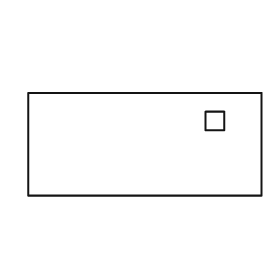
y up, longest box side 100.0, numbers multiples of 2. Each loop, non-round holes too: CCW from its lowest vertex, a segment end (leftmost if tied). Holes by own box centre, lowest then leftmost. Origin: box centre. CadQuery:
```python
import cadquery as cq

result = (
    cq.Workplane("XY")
    .moveTo(-50.0, -22.0)
    .lineTo(50.0, -22.0)
    .lineTo(50.0, 22.0)
    .lineTo(-50.0, 22.0)
    .close()
    .moveTo(26.0, 6.0)
    .lineTo(34.0, 6.0)
    .lineTo(34.0, 14.0)
    .lineTo(26.0, 14.0)
    .close()
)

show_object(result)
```